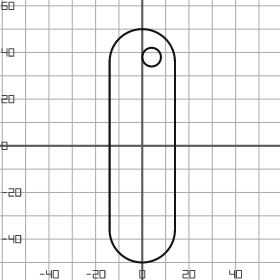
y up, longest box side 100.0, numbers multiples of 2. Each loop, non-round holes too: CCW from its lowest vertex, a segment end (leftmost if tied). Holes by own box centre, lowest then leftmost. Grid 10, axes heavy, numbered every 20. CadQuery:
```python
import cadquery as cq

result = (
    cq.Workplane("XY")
    .moveTo(-14.0, -36.0)
    .threePointArc((0.0, -50.0), (14.0, -36.0))
    .lineTo(14.0, 36.0)
    .threePointArc((0.0, 50.0), (-14.0, 36.0))
    .close()
    .moveTo(4.0, 38.0)
    .circle(4.0)
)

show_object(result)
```